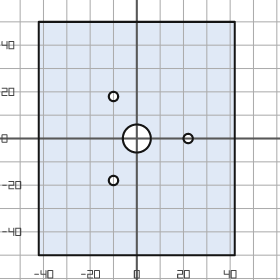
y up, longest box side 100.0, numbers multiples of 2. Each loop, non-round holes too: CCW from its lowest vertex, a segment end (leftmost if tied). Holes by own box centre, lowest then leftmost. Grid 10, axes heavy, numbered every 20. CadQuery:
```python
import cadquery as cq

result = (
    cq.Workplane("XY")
    .moveTo(-42.0, -50.0)
    .lineTo(42.0, -50.0)
    .lineTo(42.0, 50.0)
    .lineTo(-42.0, 50.0)
    .close()
    .moveTo(-10.0, -18.0)
    .circle(2.0)
    .moveTo(0.0, 0.0)
    .circle(6.0)
    .moveTo(22.0, 0.0)
    .circle(2.0)
    .moveTo(-10.0, 18.0)
    .circle(2.0)
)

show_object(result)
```